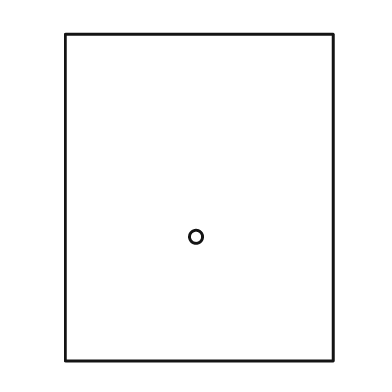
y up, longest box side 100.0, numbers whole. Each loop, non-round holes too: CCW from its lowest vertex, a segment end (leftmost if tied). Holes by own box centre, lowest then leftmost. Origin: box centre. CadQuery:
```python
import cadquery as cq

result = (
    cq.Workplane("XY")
    .moveTo(-41.0, -50.0)
    .lineTo(41.0, -50.0)
    .lineTo(41.0, 50.0)
    .lineTo(-41.0, 50.0)
    .close()
    .moveTo(-1.0, -12.0)
    .circle(2.0)
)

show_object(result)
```